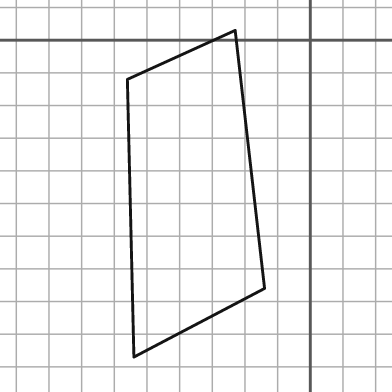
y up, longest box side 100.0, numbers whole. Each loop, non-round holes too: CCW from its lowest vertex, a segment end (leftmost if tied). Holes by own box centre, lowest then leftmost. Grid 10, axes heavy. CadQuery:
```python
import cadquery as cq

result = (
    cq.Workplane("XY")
    .moveTo(-54.0, -97.0)
    .lineTo(-14.0, -76.0)
    .lineTo(-23.0, 3.0)
    .lineTo(-56.0, -12.0)
    .close()
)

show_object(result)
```